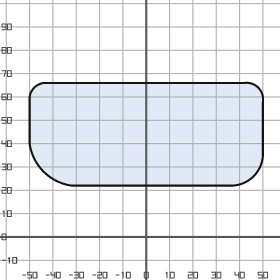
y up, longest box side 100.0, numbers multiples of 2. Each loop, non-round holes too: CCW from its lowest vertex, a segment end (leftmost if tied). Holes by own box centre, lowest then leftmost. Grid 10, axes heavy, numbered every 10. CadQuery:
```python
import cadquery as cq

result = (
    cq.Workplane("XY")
    .moveTo(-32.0, 22.0)
    .lineTo(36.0, 22.0)
    .threePointArc((46.0, 26.0), (50.0, 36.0))
    .lineTo(50.0, 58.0)
    .threePointArc((48.0, 64.0), (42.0, 66.0))
    .lineTo(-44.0, 66.0)
    .threePointArc((-48.0, 64.0), (-50.0, 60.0))
    .lineTo(-50.0, 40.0)
    .threePointArc((-44.0, 28.0), (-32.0, 22.0))
    .close()
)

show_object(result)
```